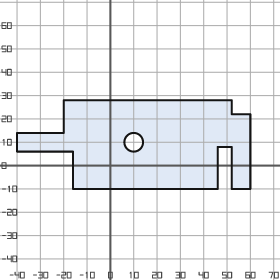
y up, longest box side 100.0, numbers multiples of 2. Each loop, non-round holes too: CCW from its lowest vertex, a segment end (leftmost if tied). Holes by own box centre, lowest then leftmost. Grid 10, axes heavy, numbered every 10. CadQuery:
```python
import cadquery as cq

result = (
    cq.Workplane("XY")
    .moveTo(-16.0, -10.0)
    .lineTo(46.0, -10.0)
    .lineTo(46.0, 8.0)
    .lineTo(52.0, 8.0)
    .lineTo(52.0, -10.0)
    .lineTo(60.0, -10.0)
    .lineTo(60.0, 22.0)
    .lineTo(52.0, 22.0)
    .lineTo(52.0, 28.0)
    .lineTo(-20.0, 28.0)
    .lineTo(-20.0, 14.0)
    .lineTo(-40.0, 14.0)
    .lineTo(-40.0, 6.0)
    .lineTo(-16.0, 6.0)
    .close()
    .moveTo(10.0, 10.0)
    .circle(4.0)
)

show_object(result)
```